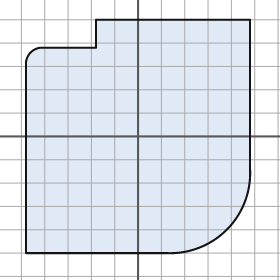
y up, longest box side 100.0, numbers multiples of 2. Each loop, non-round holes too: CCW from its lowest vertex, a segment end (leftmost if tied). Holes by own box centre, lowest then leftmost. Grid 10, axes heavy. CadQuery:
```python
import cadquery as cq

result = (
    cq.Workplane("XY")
    .moveTo(-48.0, -50.0)
    .lineTo(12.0, -50.0)
    .threePointArc((38.0, -40.0), (48.0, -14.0))
    .lineTo(48.0, 50.0)
    .lineTo(-18.0, 50.0)
    .lineTo(-18.0, 38.0)
    .lineTo(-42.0, 38.0)
    .threePointArc((-46.0, 36.0), (-48.0, 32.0))
    .close()
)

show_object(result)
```